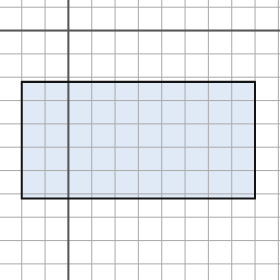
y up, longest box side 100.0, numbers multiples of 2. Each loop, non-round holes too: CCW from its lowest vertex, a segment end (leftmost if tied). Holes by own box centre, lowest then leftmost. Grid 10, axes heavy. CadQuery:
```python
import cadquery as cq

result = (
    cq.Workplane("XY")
    .moveTo(-20.0, -72.0)
    .lineTo(80.0, -72.0)
    .lineTo(80.0, -22.0)
    .lineTo(-20.0, -22.0)
    .close()
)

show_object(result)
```